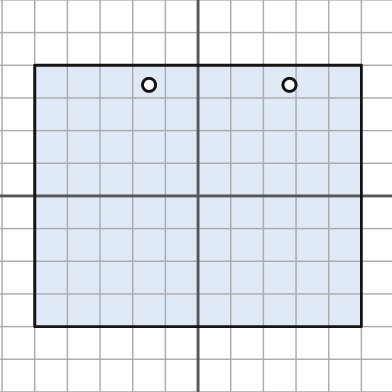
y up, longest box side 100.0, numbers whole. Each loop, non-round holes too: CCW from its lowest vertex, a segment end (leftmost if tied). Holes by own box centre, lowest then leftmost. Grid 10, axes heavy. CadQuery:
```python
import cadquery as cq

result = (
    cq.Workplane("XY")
    .moveTo(-50.0, -40.0)
    .lineTo(50.0, -40.0)
    .lineTo(50.0, 40.0)
    .lineTo(-50.0, 40.0)
    .close()
    .moveTo(-15.0, 34.0)
    .circle(2.0)
    .moveTo(28.0, 34.0)
    .circle(2.0)
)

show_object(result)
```